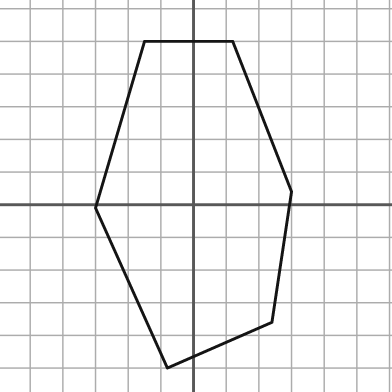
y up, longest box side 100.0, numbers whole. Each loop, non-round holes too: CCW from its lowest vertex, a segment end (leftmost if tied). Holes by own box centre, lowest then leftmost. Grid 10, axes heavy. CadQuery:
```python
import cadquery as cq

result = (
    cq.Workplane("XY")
    .moveTo(-8.0, -50.0)
    .lineTo(24.0, -36.0)
    .lineTo(30.0, 4.0)
    .lineTo(12.0, 50.0)
    .lineTo(-15.0, 50.0)
    .lineTo(-30.0, -1.0)
    .close()
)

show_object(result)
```